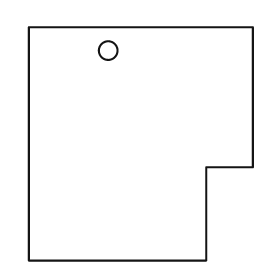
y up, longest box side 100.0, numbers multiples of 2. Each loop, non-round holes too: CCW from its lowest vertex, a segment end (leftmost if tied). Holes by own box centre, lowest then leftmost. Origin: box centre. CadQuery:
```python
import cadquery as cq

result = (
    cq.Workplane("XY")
    .moveTo(-48.0, -50.0)
    .lineTo(28.0, -50.0)
    .lineTo(28.0, -10.0)
    .lineTo(48.0, -10.0)
    .lineTo(48.0, 50.0)
    .lineTo(-48.0, 50.0)
    .close()
    .moveTo(-14.0, 40.0)
    .circle(4.0)
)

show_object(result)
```